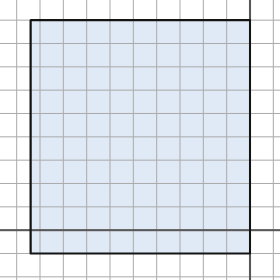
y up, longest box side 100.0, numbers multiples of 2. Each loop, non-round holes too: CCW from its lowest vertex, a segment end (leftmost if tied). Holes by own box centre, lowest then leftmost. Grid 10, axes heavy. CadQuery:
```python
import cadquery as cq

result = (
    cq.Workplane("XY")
    .moveTo(-94.0, -10.0)
    .lineTo(0.0, -10.0)
    .lineTo(0.0, 90.0)
    .lineTo(-94.0, 90.0)
    .close()
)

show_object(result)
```